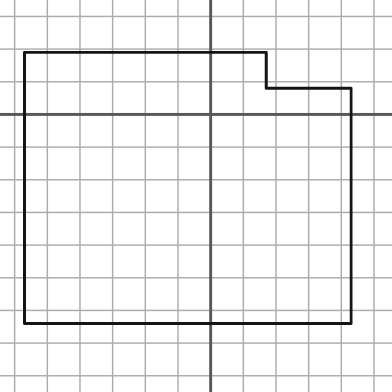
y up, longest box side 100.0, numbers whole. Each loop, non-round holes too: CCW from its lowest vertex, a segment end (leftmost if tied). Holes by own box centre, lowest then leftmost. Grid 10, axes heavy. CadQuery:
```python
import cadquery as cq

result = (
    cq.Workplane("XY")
    .moveTo(-57.0, -64.0)
    .lineTo(43.0, -64.0)
    .lineTo(43.0, 8.0)
    .lineTo(17.0, 8.0)
    .lineTo(17.0, 19.0)
    .lineTo(-57.0, 19.0)
    .close()
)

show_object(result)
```